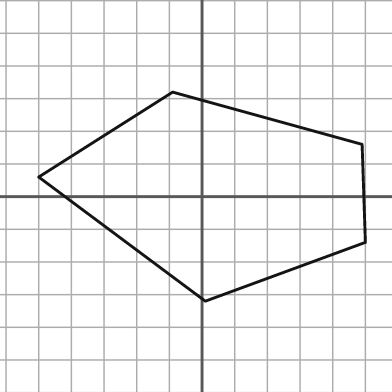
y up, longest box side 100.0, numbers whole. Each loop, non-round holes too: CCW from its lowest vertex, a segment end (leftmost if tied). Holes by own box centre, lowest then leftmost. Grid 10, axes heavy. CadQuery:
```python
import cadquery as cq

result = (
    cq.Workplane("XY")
    .moveTo(1.0, -32.0)
    .lineTo(50.0, -14.0)
    .lineTo(49.0, 16.0)
    .lineTo(-9.0, 32.0)
    .lineTo(-50.0, 6.0)
    .close()
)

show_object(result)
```